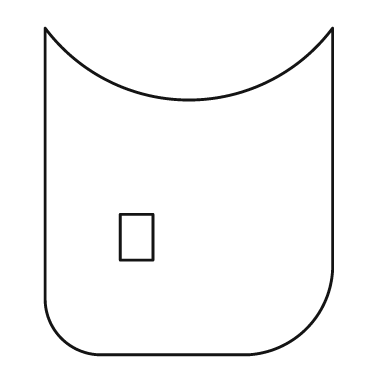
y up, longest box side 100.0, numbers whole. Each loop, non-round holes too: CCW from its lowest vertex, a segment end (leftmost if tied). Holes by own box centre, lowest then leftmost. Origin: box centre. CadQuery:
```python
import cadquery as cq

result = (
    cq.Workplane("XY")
    .moveTo(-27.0, -50.0)
    .lineTo(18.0, -50.0)
    .threePointArc((36.0, -42.0), (44.0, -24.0))
    .lineTo(44.0, 50.0)
    .threePointArc((0.0, 28.0), (-44.0, 50.0))
    .lineTo(-44.0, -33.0)
    .threePointArc((-39.0, -45.0), (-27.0, -50.0))
    .close()
    .moveTo(-21.0, -21.0)
    .lineTo(-11.0, -21.0)
    .lineTo(-11.0, -7.0)
    .lineTo(-21.0, -7.0)
    .close()
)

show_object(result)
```